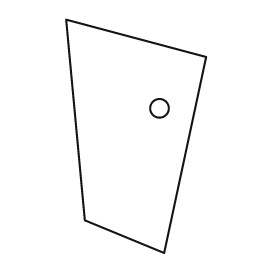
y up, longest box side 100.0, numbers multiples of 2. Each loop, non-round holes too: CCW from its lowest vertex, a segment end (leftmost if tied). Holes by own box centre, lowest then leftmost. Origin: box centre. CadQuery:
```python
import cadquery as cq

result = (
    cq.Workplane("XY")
    .moveTo(12.0, -50.0)
    .lineTo(30.0, 34.0)
    .lineTo(-30.0, 50.0)
    .lineTo(-22.0, -36.0)
    .close()
    .moveTo(10.0, 12.0)
    .circle(4.0)
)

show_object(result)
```